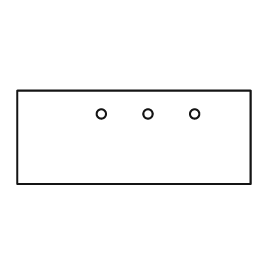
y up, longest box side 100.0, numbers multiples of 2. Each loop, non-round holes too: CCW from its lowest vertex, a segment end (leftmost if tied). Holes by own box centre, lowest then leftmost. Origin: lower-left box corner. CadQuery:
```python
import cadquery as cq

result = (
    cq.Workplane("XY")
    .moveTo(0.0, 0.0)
    .lineTo(100.0, 0.0)
    .lineTo(100.0, 40.0)
    .lineTo(0.0, 40.0)
    .close()
    .moveTo(36.0, 30.0)
    .circle(2.0)
    .moveTo(56.0, 30.0)
    .circle(2.0)
    .moveTo(76.0, 30.0)
    .circle(2.0)
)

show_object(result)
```